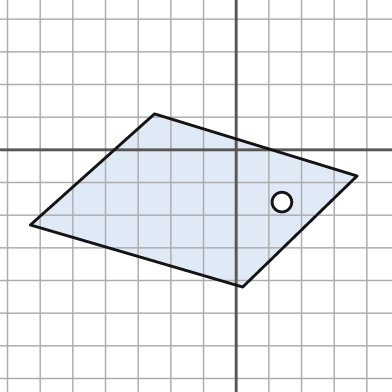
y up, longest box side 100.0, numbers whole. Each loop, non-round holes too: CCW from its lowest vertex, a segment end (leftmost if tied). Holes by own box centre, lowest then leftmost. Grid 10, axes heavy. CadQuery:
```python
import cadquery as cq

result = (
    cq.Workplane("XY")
    .moveTo(2.0, -42.0)
    .lineTo(37.0, -8.0)
    .lineTo(-25.0, 11.0)
    .lineTo(-63.0, -23.0)
    .close()
    .moveTo(14.0, -16.0)
    .circle(3.0)
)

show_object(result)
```